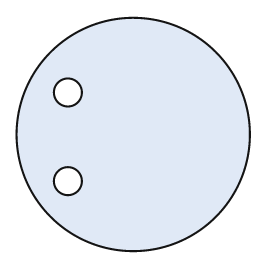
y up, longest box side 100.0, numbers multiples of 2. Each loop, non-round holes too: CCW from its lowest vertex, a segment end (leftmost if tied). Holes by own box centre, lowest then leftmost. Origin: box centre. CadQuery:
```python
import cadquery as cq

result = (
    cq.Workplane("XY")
    .moveTo(0.0, 0.0)
    .circle(50.0)
    .moveTo(-28.0, -20.0)
    .circle(6.0)
    .moveTo(-28.0, 18.0)
    .circle(6.0)
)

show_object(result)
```